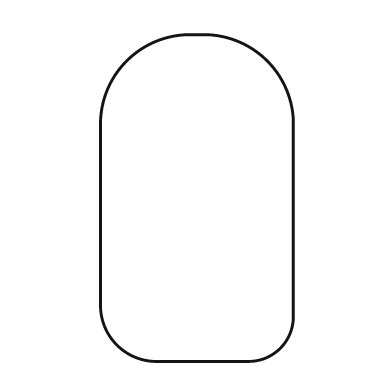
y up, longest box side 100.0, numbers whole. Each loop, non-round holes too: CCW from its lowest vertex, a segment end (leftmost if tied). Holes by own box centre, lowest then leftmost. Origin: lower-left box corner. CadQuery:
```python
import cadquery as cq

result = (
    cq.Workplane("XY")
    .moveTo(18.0, 0.0)
    .lineTo(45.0, 0.0)
    .threePointArc((55.0, 4.0), (59.0, 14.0))
    .lineTo(59.0, 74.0)
    .threePointArc((51.0, 92.0), (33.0, 100.0))
    .lineTo(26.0, 100.0)
    .threePointArc((8.0, 92.0), (0.0, 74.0))
    .lineTo(0.0, 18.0)
    .threePointArc((5.0, 5.0), (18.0, 0.0))
    .close()
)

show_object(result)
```